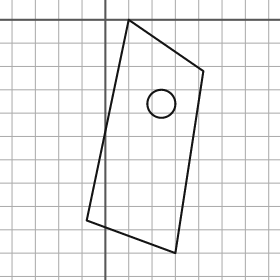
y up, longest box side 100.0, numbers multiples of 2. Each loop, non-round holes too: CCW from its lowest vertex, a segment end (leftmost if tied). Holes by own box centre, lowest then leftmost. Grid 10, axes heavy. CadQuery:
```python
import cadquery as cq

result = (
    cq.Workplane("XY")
    .moveTo(30.0, -100.0)
    .lineTo(42.0, -22.0)
    .lineTo(10.0, 0.0)
    .lineTo(-8.0, -86.0)
    .close()
    .moveTo(24.0, -36.0)
    .circle(6.0)
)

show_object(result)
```